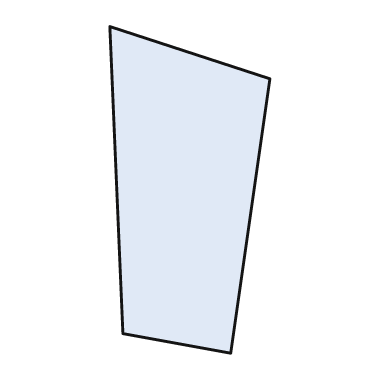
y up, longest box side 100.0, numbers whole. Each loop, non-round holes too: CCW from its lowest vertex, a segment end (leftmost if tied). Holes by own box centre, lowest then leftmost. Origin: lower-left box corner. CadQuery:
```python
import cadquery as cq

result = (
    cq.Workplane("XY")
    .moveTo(37.0, 0.0)
    .lineTo(49.0, 84.0)
    .lineTo(0.0, 100.0)
    .lineTo(4.0, 6.0)
    .close()
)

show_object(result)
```